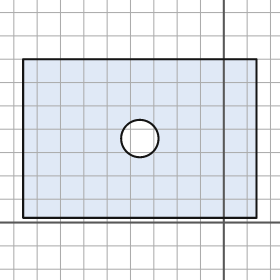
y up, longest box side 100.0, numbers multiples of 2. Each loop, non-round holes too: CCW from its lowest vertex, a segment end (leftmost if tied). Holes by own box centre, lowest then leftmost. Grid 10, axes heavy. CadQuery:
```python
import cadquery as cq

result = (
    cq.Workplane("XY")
    .moveTo(-86.0, 2.0)
    .lineTo(14.0, 2.0)
    .lineTo(14.0, 70.0)
    .lineTo(-86.0, 70.0)
    .close()
    .moveTo(-36.0, 36.0)
    .circle(8.0)
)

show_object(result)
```